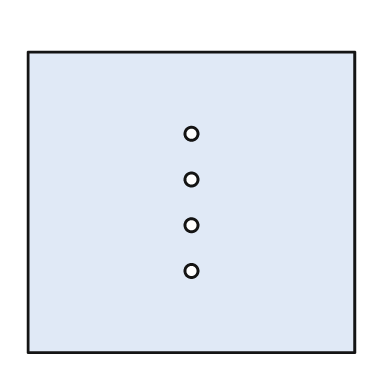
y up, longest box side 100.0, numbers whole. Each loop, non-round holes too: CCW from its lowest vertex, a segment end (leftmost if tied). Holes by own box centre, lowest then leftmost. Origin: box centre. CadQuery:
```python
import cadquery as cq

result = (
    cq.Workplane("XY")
    .moveTo(-50.0, -46.0)
    .lineTo(50.0, -46.0)
    .lineTo(50.0, 46.0)
    .lineTo(-50.0, 46.0)
    .close()
    .moveTo(0.0, -21.0)
    .circle(2.0)
    .moveTo(0.0, -7.0)
    .circle(2.0)
    .moveTo(0.0, 7.0)
    .circle(2.0)
    .moveTo(0.0, 21.0)
    .circle(2.0)
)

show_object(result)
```